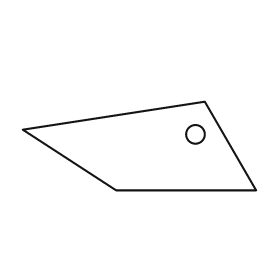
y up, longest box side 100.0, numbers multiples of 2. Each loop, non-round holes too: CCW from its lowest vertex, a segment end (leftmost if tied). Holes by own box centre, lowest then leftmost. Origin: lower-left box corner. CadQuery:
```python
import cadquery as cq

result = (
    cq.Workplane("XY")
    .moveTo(40.0, 0.0)
    .lineTo(100.0, 0.0)
    .lineTo(78.0, 38.0)
    .lineTo(0.0, 26.0)
    .close()
    .moveTo(74.0, 24.0)
    .circle(4.0)
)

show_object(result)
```